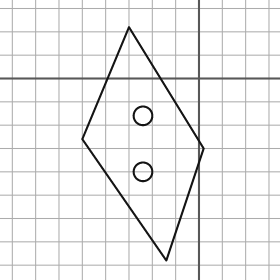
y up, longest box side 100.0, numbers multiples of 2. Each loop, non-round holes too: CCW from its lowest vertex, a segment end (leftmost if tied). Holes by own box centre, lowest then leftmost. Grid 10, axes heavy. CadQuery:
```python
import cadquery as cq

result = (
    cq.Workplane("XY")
    .moveTo(-14.0, -78.0)
    .lineTo(2.0, -30.0)
    .lineTo(-30.0, 22.0)
    .lineTo(-50.0, -26.0)
    .close()
    .moveTo(-24.0, -40.0)
    .circle(4.0)
    .moveTo(-24.0, -16.0)
    .circle(4.0)
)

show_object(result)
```